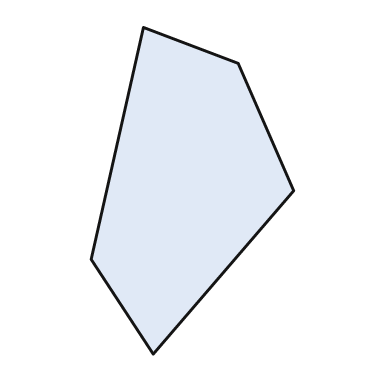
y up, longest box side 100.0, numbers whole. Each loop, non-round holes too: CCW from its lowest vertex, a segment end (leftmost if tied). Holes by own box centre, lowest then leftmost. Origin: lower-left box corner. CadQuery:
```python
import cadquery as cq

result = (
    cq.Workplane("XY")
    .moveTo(19.0, 0.0)
    .lineTo(62.0, 50.0)
    .lineTo(45.0, 89.0)
    .lineTo(16.0, 100.0)
    .lineTo(0.0, 29.0)
    .close()
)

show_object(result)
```